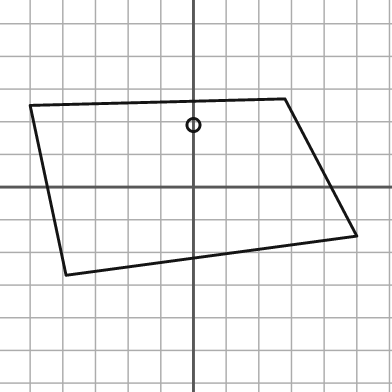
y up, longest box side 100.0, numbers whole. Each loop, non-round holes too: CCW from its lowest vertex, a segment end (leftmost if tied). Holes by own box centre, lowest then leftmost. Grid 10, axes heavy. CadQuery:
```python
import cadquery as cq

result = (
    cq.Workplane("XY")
    .moveTo(-39.0, -27.0)
    .lineTo(50.0, -15.0)
    .lineTo(28.0, 27.0)
    .lineTo(-50.0, 25.0)
    .close()
    .moveTo(0.0, 19.0)
    .circle(2.0)
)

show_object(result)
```